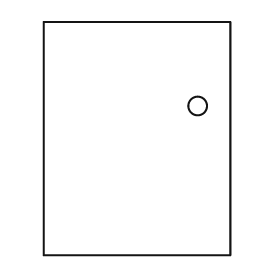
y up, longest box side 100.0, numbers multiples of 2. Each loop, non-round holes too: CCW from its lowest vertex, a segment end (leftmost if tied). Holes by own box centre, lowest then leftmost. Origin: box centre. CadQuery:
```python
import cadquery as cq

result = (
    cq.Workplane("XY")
    .moveTo(-40.0, -50.0)
    .lineTo(40.0, -50.0)
    .lineTo(40.0, 50.0)
    .lineTo(-40.0, 50.0)
    .close()
    .moveTo(26.0, 14.0)
    .circle(4.0)
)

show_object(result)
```